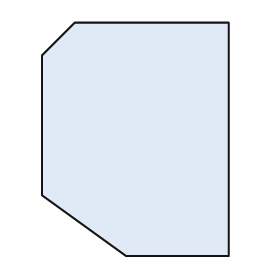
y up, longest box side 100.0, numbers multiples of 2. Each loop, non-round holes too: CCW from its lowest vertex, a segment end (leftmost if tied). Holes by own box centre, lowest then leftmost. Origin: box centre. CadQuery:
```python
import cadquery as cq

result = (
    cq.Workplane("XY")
    .moveTo(-4.0, -50.0)
    .lineTo(40.0, -50.0)
    .lineTo(40.0, 50.0)
    .lineTo(-26.0, 50.0)
    .lineTo(-40.0, 36.0)
    .lineTo(-40.0, -24.0)
    .close()
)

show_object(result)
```